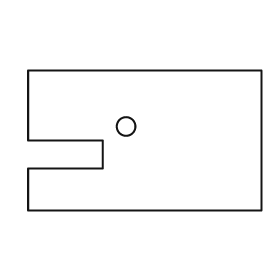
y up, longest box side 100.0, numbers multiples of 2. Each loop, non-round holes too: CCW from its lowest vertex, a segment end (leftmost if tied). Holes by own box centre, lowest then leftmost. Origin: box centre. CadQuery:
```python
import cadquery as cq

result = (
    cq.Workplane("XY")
    .moveTo(-50.0, -30.0)
    .lineTo(50.0, -30.0)
    .lineTo(50.0, 30.0)
    .lineTo(-50.0, 30.0)
    .lineTo(-50.0, 0.0)
    .lineTo(-18.0, 0.0)
    .lineTo(-18.0, -12.0)
    .lineTo(-50.0, -12.0)
    .close()
    .moveTo(-8.0, 6.0)
    .circle(4.0)
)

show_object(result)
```